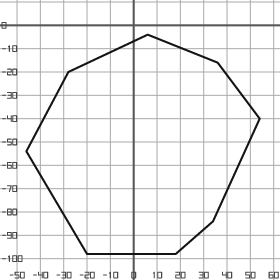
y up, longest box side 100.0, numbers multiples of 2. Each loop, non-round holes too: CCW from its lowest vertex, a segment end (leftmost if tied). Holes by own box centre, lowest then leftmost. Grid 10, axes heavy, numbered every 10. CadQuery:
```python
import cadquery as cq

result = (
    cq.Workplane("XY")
    .moveTo(-20.0, -98.0)
    .lineTo(18.0, -98.0)
    .lineTo(34.0, -84.0)
    .lineTo(54.0, -40.0)
    .lineTo(36.0, -16.0)
    .lineTo(6.0, -4.0)
    .lineTo(-28.0, -20.0)
    .lineTo(-46.0, -54.0)
    .close()
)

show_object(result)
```